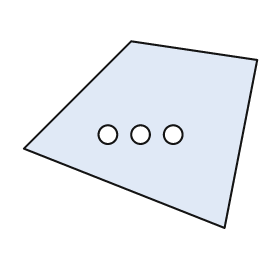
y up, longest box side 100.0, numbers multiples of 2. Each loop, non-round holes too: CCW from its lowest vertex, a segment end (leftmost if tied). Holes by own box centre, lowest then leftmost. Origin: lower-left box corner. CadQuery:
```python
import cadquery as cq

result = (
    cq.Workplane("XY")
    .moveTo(86.0, 0.0)
    .lineTo(100.0, 72.0)
    .lineTo(46.0, 80.0)
    .lineTo(0.0, 34.0)
    .close()
    .moveTo(36.0, 40.0)
    .circle(4.0)
    .moveTo(50.0, 40.0)
    .circle(4.0)
    .moveTo(64.0, 40.0)
    .circle(4.0)
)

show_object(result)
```